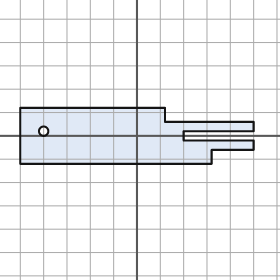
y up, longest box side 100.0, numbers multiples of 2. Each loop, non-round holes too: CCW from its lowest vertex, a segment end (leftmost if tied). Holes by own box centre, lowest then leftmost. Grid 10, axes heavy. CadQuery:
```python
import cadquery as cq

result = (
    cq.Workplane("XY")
    .moveTo(-50.0, -12.0)
    .lineTo(32.0, -12.0)
    .lineTo(32.0, -6.0)
    .lineTo(50.0, -6.0)
    .lineTo(50.0, -2.0)
    .lineTo(20.0, -2.0)
    .lineTo(20.0, 2.0)
    .lineTo(50.0, 2.0)
    .lineTo(50.0, 6.0)
    .lineTo(12.0, 6.0)
    .lineTo(12.0, 12.0)
    .lineTo(-50.0, 12.0)
    .close()
    .moveTo(-40.0, 2.0)
    .circle(2.0)
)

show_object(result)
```